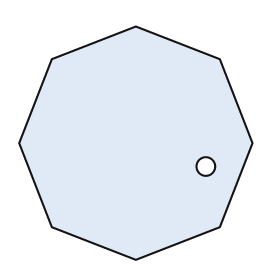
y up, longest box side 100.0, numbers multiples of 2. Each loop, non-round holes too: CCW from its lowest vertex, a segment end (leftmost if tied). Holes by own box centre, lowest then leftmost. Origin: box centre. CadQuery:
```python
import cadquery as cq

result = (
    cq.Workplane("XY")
    .moveTo(0.0, -50.0)
    .lineTo(36.0, -36.0)
    .lineTo(50.0, 0.0)
    .lineTo(36.0, 36.0)
    .lineTo(0.0, 50.0)
    .lineTo(-36.0, 36.0)
    .lineTo(-50.0, 0.0)
    .lineTo(-36.0, -36.0)
    .close()
    .moveTo(30.0, -10.0)
    .circle(4.0)
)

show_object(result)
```